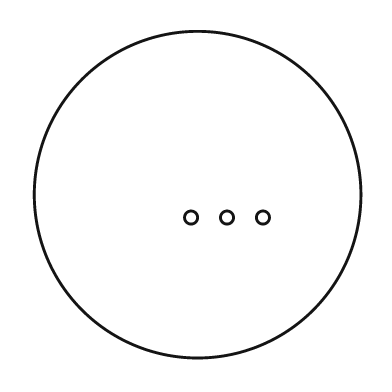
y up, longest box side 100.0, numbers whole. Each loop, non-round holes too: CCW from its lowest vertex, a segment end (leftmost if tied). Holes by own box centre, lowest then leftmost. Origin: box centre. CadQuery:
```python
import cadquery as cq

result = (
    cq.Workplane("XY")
    .moveTo(0.0, 0.0)
    .circle(50.0)
    .moveTo(-2.0, -7.0)
    .circle(2.0)
    .moveTo(9.0, -7.0)
    .circle(2.0)
    .moveTo(20.0, -7.0)
    .circle(2.0)
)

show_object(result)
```